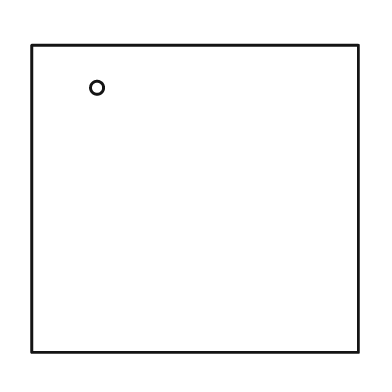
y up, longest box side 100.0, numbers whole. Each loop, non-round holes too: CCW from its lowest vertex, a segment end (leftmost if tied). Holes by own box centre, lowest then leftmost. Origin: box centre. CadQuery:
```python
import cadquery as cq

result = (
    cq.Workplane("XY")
    .moveTo(-50.0, -47.0)
    .lineTo(50.0, -47.0)
    .lineTo(50.0, 47.0)
    .lineTo(-50.0, 47.0)
    .close()
    .moveTo(-30.0, 34.0)
    .circle(2.0)
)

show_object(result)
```